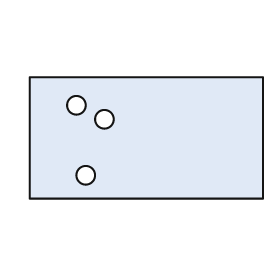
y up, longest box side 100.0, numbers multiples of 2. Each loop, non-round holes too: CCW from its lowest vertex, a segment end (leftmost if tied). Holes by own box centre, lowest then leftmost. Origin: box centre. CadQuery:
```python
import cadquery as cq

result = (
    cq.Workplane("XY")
    .moveTo(-50.0, -26.0)
    .lineTo(50.0, -26.0)
    .lineTo(50.0, 26.0)
    .lineTo(-50.0, 26.0)
    .close()
    .moveTo(-26.0, -16.0)
    .circle(4.0)
    .moveTo(-18.0, 8.0)
    .circle(4.0)
    .moveTo(-30.0, 14.0)
    .circle(4.0)
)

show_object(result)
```